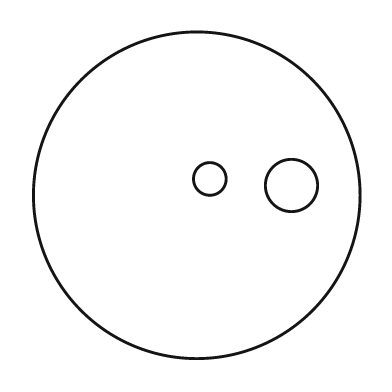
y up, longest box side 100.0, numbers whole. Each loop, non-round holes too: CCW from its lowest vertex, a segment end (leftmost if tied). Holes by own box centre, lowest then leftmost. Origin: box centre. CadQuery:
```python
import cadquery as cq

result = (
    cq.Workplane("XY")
    .moveTo(0.0, 0.0)
    .circle(50.0)
    .moveTo(29.0, 3.0)
    .circle(8.0)
    .moveTo(4.0, 5.0)
    .circle(5.0)
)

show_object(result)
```